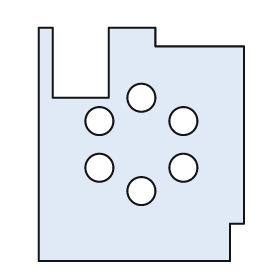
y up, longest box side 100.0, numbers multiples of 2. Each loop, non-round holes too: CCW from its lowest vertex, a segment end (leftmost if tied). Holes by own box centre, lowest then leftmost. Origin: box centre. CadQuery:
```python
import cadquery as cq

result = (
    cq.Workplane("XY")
    .moveTo(-44.0, -50.0)
    .lineTo(38.0, -50.0)
    .lineTo(38.0, -34.0)
    .lineTo(44.0, -34.0)
    .lineTo(44.0, 42.0)
    .lineTo(6.0, 42.0)
    .lineTo(6.0, 50.0)
    .lineTo(-14.0, 50.0)
    .lineTo(-14.0, 20.0)
    .lineTo(-38.0, 20.0)
    .lineTo(-38.0, 50.0)
    .lineTo(-44.0, 50.0)
    .close()
    .moveTo(0.0, -20.0)
    .circle(6.0)
    .moveTo(-18.0, -10.0)
    .circle(6.0)
    .moveTo(18.0, -10.0)
    .circle(6.0)
    .moveTo(-18.0, 10.0)
    .circle(6.0)
    .moveTo(18.0, 10.0)
    .circle(6.0)
    .moveTo(0.0, 20.0)
    .circle(6.0)
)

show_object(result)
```